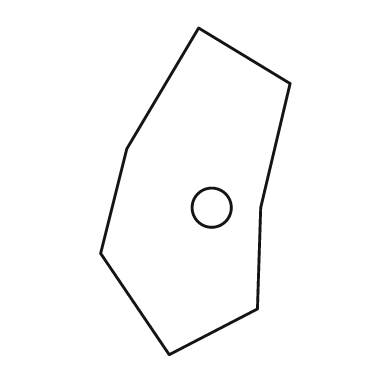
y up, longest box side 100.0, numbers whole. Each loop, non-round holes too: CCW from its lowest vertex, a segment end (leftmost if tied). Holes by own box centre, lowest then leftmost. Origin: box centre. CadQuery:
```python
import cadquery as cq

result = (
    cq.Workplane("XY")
    .moveTo(-8.0, -50.0)
    .lineTo(19.0, -36.0)
    .lineTo(20.0, -5.0)
    .lineTo(29.0, 33.0)
    .lineTo(1.0, 50.0)
    .lineTo(-21.0, 13.0)
    .lineTo(-29.0, -19.0)
    .close()
    .moveTo(5.0, -5.0)
    .circle(6.0)
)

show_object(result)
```